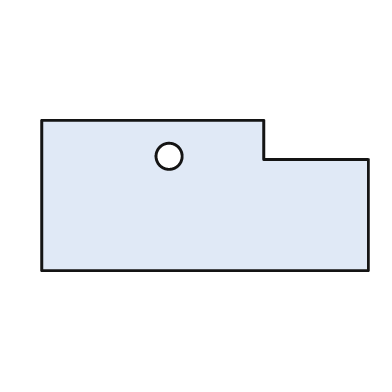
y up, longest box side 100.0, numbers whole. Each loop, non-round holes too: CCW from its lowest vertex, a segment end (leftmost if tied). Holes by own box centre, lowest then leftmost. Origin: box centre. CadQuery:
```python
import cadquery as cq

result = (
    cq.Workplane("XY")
    .moveTo(-50.0, -23.0)
    .lineTo(50.0, -23.0)
    .lineTo(50.0, 11.0)
    .lineTo(18.0, 11.0)
    .lineTo(18.0, 23.0)
    .lineTo(-50.0, 23.0)
    .close()
    .moveTo(-11.0, 12.0)
    .circle(4.0)
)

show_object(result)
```